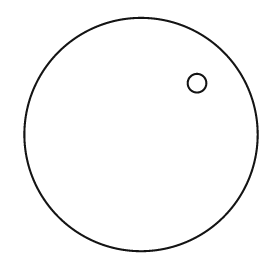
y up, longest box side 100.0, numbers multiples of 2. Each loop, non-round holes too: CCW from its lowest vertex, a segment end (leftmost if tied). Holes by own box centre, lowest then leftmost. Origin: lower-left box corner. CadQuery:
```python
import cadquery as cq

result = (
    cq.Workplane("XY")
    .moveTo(50.0, 50.0)
    .circle(50.0)
    .moveTo(74.0, 72.0)
    .circle(4.0)
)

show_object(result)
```